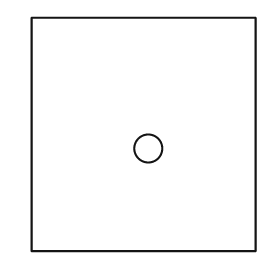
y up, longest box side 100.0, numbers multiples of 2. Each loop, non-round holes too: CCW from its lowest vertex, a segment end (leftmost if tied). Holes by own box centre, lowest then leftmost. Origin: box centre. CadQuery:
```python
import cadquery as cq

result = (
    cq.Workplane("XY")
    .moveTo(-48.0, -50.0)
    .lineTo(48.0, -50.0)
    .lineTo(48.0, 50.0)
    .lineTo(-48.0, 50.0)
    .close()
    .moveTo(2.0, -6.0)
    .circle(6.0)
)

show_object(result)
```